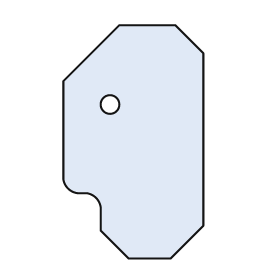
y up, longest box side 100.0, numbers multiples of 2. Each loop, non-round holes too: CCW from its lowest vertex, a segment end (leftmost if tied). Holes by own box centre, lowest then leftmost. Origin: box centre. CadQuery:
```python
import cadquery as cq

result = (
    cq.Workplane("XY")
    .moveTo(-2.0, -50.0)
    .lineTo(16.0, -50.0)
    .lineTo(30.0, -36.0)
    .lineTo(30.0, 38.0)
    .lineTo(18.0, 50.0)
    .lineTo(-6.0, 50.0)
    .lineTo(-30.0, 26.0)
    .lineTo(-30.0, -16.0)
    .threePointArc((-28.0, -20.0), (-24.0, -22.0))
    .lineTo(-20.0, -22.0)
    .threePointArc((-16.0, -24.0), (-14.0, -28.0))
    .lineTo(-14.0, -38.0)
    .close()
    .moveTo(-10.0, 16.0)
    .circle(4.0)
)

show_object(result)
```